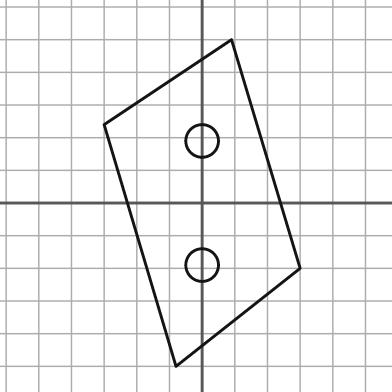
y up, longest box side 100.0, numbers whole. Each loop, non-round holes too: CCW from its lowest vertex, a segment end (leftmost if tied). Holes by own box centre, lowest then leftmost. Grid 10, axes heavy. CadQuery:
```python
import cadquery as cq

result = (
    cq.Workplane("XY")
    .moveTo(-8.0, -50.0)
    .lineTo(30.0, -20.0)
    .lineTo(9.0, 50.0)
    .lineTo(-30.0, 24.0)
    .close()
    .moveTo(0.0, -19.0)
    .circle(5.0)
    .moveTo(0.0, 19.0)
    .circle(5.0)
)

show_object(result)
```